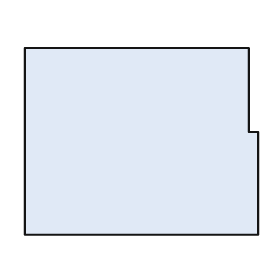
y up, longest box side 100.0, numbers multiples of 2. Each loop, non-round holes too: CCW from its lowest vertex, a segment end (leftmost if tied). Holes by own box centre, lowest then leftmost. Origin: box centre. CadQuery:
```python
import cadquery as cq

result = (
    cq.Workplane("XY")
    .moveTo(-50.0, -40.0)
    .lineTo(50.0, -40.0)
    .lineTo(50.0, 4.0)
    .lineTo(46.0, 4.0)
    .lineTo(46.0, 40.0)
    .lineTo(-50.0, 40.0)
    .close()
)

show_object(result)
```